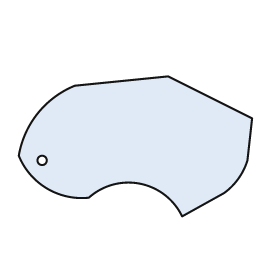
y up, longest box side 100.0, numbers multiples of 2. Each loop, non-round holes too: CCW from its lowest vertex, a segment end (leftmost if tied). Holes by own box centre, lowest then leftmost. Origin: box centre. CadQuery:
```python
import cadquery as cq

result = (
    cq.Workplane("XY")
    .moveTo(20.0, -30.0)
    .lineTo(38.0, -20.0)
    .threePointArc((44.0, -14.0), (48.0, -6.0))
    .lineTo(50.0, 12.0)
    .lineTo(14.0, 30.0)
    .lineTo(-26.0, 26.0)
    .threePointArc((-42.0, 14.0), (-50.0, -4.0))
    .threePointArc((-38.0, -18.0), (-20.0, -22.0))
    .threePointArc((2.0, -16.0), (20.0, -30.0))
    .close()
    .moveTo(-40.0, -6.0)
    .circle(2.0)
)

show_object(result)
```